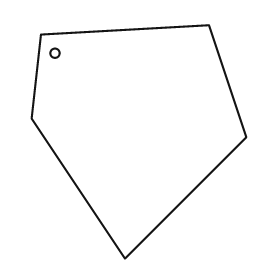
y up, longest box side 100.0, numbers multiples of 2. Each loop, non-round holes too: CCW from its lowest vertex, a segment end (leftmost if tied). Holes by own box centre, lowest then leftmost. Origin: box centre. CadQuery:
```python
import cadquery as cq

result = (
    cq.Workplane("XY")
    .moveTo(-6.0, -50.0)
    .lineTo(46.0, 2.0)
    .lineTo(30.0, 50.0)
    .lineTo(-42.0, 46.0)
    .lineTo(-46.0, 10.0)
    .close()
    .moveTo(-36.0, 38.0)
    .circle(2.0)
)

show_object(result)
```